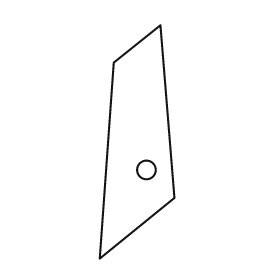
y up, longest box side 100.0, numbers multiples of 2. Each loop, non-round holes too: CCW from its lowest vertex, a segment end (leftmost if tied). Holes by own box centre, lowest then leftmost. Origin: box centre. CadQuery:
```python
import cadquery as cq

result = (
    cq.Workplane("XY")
    .moveTo(-16.0, -50.0)
    .lineTo(16.0, -24.0)
    .lineTo(10.0, 50.0)
    .lineTo(-10.0, 34.0)
    .close()
    .moveTo(4.0, -12.0)
    .circle(4.0)
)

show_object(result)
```